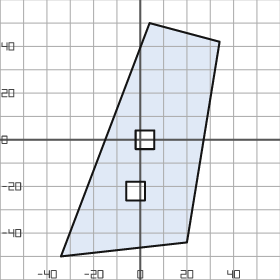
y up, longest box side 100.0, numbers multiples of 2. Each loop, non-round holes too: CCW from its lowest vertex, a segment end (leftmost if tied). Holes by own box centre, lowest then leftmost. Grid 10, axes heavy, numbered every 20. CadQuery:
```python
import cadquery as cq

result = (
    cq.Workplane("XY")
    .moveTo(-34.0, -50.0)
    .lineTo(20.0, -44.0)
    .lineTo(34.0, 42.0)
    .lineTo(4.0, 50.0)
    .close()
    .moveTo(-6.0, -26.0)
    .lineTo(2.0, -26.0)
    .lineTo(2.0, -18.0)
    .lineTo(-6.0, -18.0)
    .close()
    .moveTo(-2.0, -4.0)
    .lineTo(6.0, -4.0)
    .lineTo(6.0, 4.0)
    .lineTo(-2.0, 4.0)
    .close()
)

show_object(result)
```